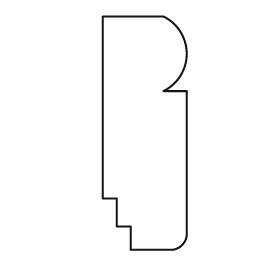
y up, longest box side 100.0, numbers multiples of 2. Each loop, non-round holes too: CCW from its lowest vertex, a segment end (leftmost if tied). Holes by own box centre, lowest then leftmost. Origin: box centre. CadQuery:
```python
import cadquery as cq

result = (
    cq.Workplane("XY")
    .moveTo(-6.0, -50.0)
    .lineTo(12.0, -50.0)
    .threePointArc((16.0, -48.0), (18.0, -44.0))
    .lineTo(18.0, 18.0)
    .lineTo(8.0, 18.0)
    .threePointArc((18.0, 34.0), (8.0, 50.0))
    .lineTo(-18.0, 50.0)
    .lineTo(-18.0, -28.0)
    .lineTo(-12.0, -28.0)
    .lineTo(-12.0, -40.0)
    .lineTo(-6.0, -40.0)
    .close()
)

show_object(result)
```